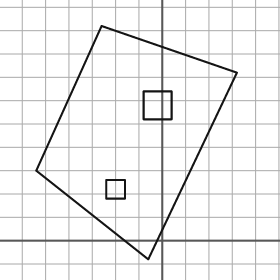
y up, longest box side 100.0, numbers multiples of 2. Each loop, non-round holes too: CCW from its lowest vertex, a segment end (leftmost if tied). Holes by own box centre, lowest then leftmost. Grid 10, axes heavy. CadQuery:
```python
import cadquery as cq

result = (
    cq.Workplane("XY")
    .moveTo(-6.0, -8.0)
    .lineTo(32.0, 72.0)
    .lineTo(-26.0, 92.0)
    .lineTo(-54.0, 30.0)
    .close()
    .moveTo(-24.0, 18.0)
    .lineTo(-16.0, 18.0)
    .lineTo(-16.0, 26.0)
    .lineTo(-24.0, 26.0)
    .close()
    .moveTo(-8.0, 52.0)
    .lineTo(4.0, 52.0)
    .lineTo(4.0, 64.0)
    .lineTo(-8.0, 64.0)
    .close()
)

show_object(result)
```